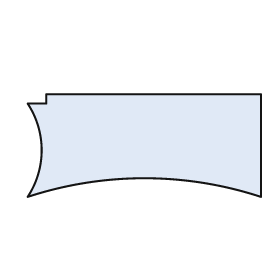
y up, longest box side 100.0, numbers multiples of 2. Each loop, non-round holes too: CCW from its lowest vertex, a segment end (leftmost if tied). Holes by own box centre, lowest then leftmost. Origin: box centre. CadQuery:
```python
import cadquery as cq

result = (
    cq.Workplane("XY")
    .moveTo(-50.0, -22.0)
    .threePointArc((0.0, -14.0), (50.0, -22.0))
    .lineTo(50.0, 22.0)
    .lineTo(-42.0, 22.0)
    .lineTo(-42.0, 18.0)
    .lineTo(-50.0, 18.0)
    .threePointArc((-44.0, -2.0), (-50.0, -22.0))
    .close()
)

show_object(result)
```